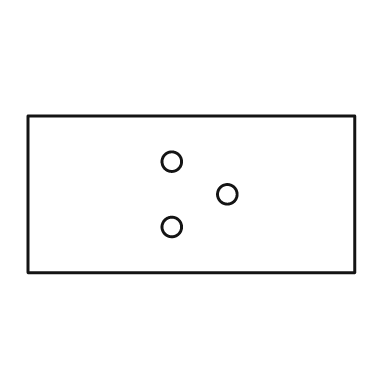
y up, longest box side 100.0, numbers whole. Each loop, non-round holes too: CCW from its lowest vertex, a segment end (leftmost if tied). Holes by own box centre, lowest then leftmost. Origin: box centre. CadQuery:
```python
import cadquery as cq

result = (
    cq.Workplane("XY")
    .moveTo(-50.0, -24.0)
    .lineTo(50.0, -24.0)
    .lineTo(50.0, 24.0)
    .lineTo(-50.0, 24.0)
    .close()
    .moveTo(-6.0, -10.0)
    .circle(3.0)
    .moveTo(11.0, 0.0)
    .circle(3.0)
    .moveTo(-6.0, 10.0)
    .circle(3.0)
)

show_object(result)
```